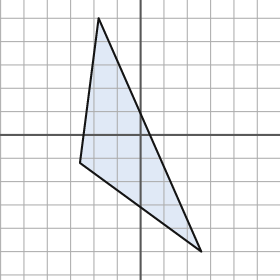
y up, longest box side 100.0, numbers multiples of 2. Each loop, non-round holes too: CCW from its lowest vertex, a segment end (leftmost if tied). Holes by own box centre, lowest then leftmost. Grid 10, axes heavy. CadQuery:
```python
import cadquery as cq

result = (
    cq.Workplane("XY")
    .moveTo(26.0, -50.0)
    .lineTo(-18.0, 50.0)
    .lineTo(-26.0, -12.0)
    .close()
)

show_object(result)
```